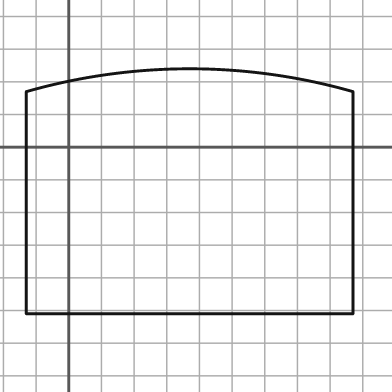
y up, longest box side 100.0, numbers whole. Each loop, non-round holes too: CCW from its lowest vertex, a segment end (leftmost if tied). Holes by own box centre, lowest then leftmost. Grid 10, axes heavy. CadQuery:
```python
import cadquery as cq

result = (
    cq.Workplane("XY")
    .moveTo(-13.0, -51.0)
    .lineTo(87.0, -51.0)
    .lineTo(87.0, 17.0)
    .threePointArc((37.0, 24.0), (-13.0, 17.0))
    .close()
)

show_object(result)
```